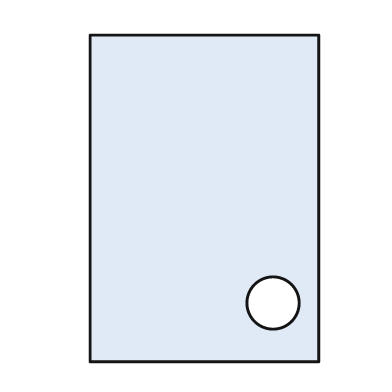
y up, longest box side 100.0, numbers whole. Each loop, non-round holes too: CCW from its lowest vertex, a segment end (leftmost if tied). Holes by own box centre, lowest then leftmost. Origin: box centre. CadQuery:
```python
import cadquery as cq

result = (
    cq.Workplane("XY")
    .moveTo(-35.0, -50.0)
    .lineTo(35.0, -50.0)
    .lineTo(35.0, 50.0)
    .lineTo(-35.0, 50.0)
    .close()
    .moveTo(21.0, -32.0)
    .circle(8.0)
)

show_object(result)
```